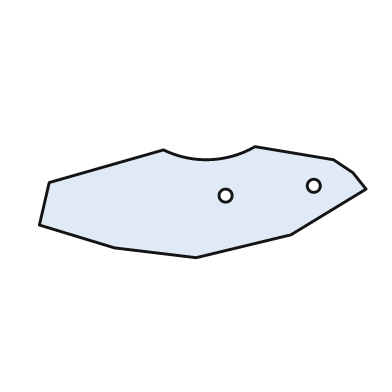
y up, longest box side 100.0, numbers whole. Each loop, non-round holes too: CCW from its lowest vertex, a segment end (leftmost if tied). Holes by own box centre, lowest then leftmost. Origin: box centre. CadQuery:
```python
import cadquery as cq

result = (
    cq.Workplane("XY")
    .moveTo(-2.0, -17.0)
    .lineTo(27.0, -10.0)
    .lineTo(50.0, 4.0)
    .lineTo(46.0, 9.0)
    .lineTo(40.0, 13.0)
    .lineTo(16.0, 17.0)
    .threePointArc((2.0, 13.0), (-12.0, 16.0))
    .lineTo(-47.0, 6.0)
    .lineTo(-50.0, -7.0)
    .lineTo(-27.0, -14.0)
    .close()
    .moveTo(7.0, 2.0)
    .circle(2.0)
    .moveTo(34.0, 5.0)
    .circle(2.0)
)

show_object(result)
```